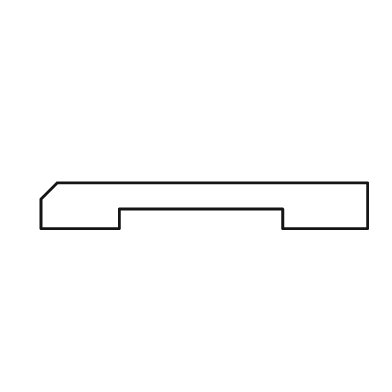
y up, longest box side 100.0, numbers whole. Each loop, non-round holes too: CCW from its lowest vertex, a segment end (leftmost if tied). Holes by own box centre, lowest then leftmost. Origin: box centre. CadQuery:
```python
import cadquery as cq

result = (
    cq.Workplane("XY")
    .moveTo(-50.0, -7.0)
    .lineTo(-26.0, -7.0)
    .lineTo(-26.0, -1.0)
    .lineTo(24.0, -1.0)
    .lineTo(24.0, -7.0)
    .lineTo(50.0, -7.0)
    .lineTo(50.0, 7.0)
    .lineTo(-45.0, 7.0)
    .lineTo(-50.0, 2.0)
    .close()
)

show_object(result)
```